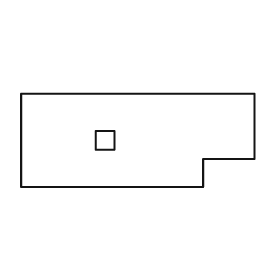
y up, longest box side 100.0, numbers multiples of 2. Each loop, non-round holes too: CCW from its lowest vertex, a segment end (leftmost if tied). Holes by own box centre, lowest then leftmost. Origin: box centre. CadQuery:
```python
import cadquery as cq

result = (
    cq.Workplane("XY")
    .moveTo(-50.0, -20.0)
    .lineTo(28.0, -20.0)
    .lineTo(28.0, -8.0)
    .lineTo(50.0, -8.0)
    .lineTo(50.0, 20.0)
    .lineTo(-50.0, 20.0)
    .close()
    .moveTo(-18.0, -4.0)
    .lineTo(-10.0, -4.0)
    .lineTo(-10.0, 4.0)
    .lineTo(-18.0, 4.0)
    .close()
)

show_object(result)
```